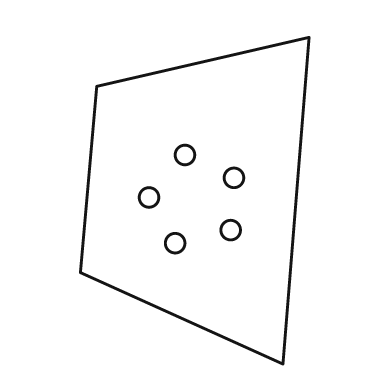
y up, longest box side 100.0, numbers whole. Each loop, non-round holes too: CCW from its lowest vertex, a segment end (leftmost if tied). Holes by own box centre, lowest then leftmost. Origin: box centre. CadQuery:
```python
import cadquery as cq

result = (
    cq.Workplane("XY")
    .moveTo(27.0, -50.0)
    .lineTo(35.0, 50.0)
    .lineTo(-30.0, 35.0)
    .lineTo(-35.0, -22.0)
    .close()
    .moveTo(-6.0, -13.0)
    .circle(3.0)
    .moveTo(11.0, -9.0)
    .circle(3.0)
    .moveTo(-14.0, 1.0)
    .circle(3.0)
    .moveTo(12.0, 7.0)
    .circle(3.0)
    .moveTo(-3.0, 14.0)
    .circle(3.0)
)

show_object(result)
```